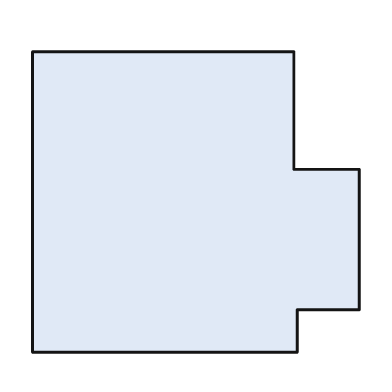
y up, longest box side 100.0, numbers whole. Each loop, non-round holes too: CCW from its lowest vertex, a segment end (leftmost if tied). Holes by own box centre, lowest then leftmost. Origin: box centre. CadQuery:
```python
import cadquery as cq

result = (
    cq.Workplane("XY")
    .moveTo(-50.0, -46.0)
    .lineTo(31.0, -46.0)
    .lineTo(31.0, -33.0)
    .lineTo(50.0, -33.0)
    .lineTo(50.0, 10.0)
    .lineTo(30.0, 10.0)
    .lineTo(30.0, 46.0)
    .lineTo(-50.0, 46.0)
    .close()
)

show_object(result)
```